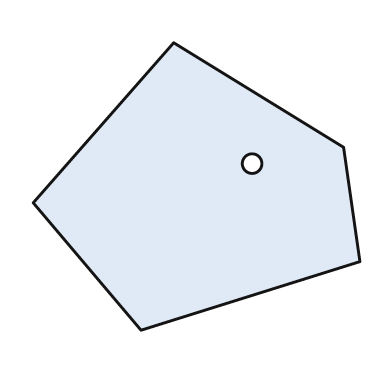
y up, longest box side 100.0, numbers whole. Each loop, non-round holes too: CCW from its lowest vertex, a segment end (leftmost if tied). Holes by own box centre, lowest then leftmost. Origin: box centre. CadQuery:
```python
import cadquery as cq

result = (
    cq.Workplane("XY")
    .moveTo(-17.0, -44.0)
    .lineTo(50.0, -23.0)
    .lineTo(45.0, 12.0)
    .lineTo(-7.0, 44.0)
    .lineTo(-50.0, -5.0)
    .close()
    .moveTo(17.0, 7.0)
    .circle(3.0)
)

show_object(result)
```